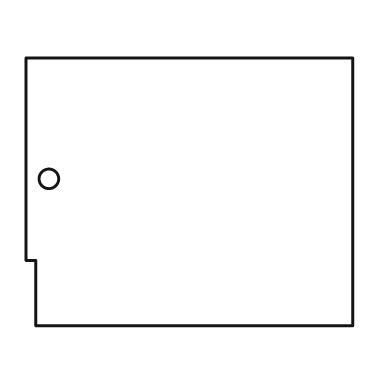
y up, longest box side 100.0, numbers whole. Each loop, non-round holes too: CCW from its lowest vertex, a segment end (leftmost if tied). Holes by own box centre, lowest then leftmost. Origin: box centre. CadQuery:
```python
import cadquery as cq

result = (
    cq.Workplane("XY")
    .moveTo(-47.0, -41.0)
    .lineTo(50.0, -41.0)
    .lineTo(50.0, 41.0)
    .lineTo(-50.0, 41.0)
    .lineTo(-50.0, -21.0)
    .lineTo(-47.0, -21.0)
    .close()
    .moveTo(-43.0, 4.0)
    .circle(3.0)
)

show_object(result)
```